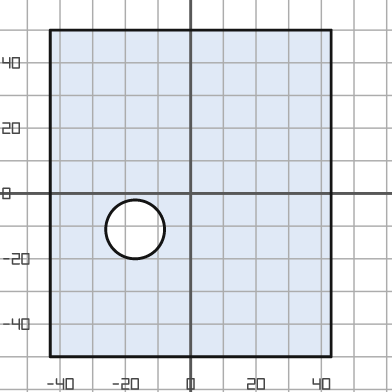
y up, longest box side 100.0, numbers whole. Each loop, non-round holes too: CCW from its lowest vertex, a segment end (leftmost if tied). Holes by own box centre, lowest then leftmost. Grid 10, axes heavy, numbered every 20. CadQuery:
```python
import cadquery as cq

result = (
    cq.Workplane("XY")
    .moveTo(-43.0, -50.0)
    .lineTo(43.0, -50.0)
    .lineTo(43.0, 50.0)
    .lineTo(-43.0, 50.0)
    .close()
    .moveTo(-17.0, -11.0)
    .circle(9.0)
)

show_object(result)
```